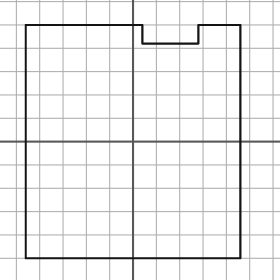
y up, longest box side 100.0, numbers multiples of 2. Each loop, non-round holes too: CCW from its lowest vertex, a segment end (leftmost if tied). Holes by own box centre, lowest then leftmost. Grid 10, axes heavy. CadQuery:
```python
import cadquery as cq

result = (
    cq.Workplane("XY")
    .moveTo(-46.0, -50.0)
    .lineTo(46.0, -50.0)
    .lineTo(46.0, 50.0)
    .lineTo(28.0, 50.0)
    .lineTo(28.0, 42.0)
    .lineTo(4.0, 42.0)
    .lineTo(4.0, 50.0)
    .lineTo(-46.0, 50.0)
    .close()
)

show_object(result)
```